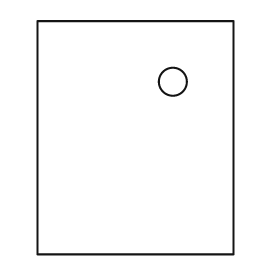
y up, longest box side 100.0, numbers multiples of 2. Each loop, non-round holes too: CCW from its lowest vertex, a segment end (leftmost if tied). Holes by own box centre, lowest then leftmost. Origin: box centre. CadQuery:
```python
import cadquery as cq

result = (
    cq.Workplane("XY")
    .moveTo(-42.0, -50.0)
    .lineTo(42.0, -50.0)
    .lineTo(42.0, 50.0)
    .lineTo(-42.0, 50.0)
    .close()
    .moveTo(16.0, 24.0)
    .circle(6.0)
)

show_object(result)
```